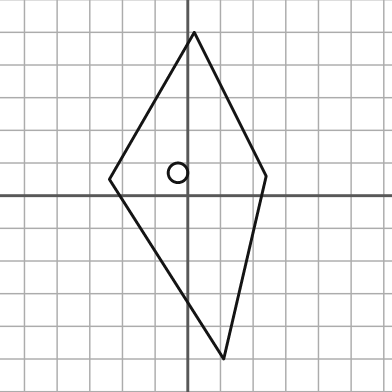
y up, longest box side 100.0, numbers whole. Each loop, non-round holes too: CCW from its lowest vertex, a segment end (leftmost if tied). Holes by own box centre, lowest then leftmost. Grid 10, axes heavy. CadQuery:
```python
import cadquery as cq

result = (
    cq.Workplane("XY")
    .moveTo(11.0, -50.0)
    .lineTo(24.0, 6.0)
    .lineTo(2.0, 50.0)
    .lineTo(-24.0, 5.0)
    .close()
    .moveTo(-3.0, 7.0)
    .circle(3.0)
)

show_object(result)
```